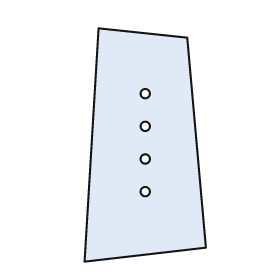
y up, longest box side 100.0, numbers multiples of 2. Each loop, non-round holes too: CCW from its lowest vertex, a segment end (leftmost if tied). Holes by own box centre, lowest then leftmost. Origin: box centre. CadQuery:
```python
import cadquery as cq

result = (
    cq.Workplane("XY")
    .moveTo(-26.0, -50.0)
    .lineTo(26.0, -44.0)
    .lineTo(18.0, 46.0)
    .lineTo(-20.0, 50.0)
    .close()
    .moveTo(0.0, -20.0)
    .circle(2.0)
    .moveTo(0.0, -6.0)
    .circle(2.0)
    .moveTo(0.0, 8.0)
    .circle(2.0)
    .moveTo(0.0, 22.0)
    .circle(2.0)
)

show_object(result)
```